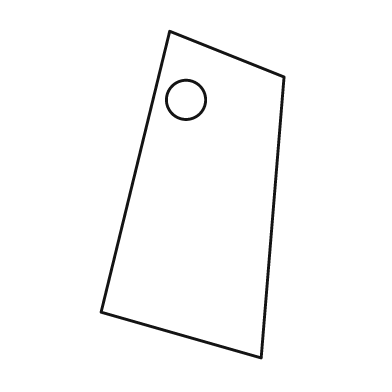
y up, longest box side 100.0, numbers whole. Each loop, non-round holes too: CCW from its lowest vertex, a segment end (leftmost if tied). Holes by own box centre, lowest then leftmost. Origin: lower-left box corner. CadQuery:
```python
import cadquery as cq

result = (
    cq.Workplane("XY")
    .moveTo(49.0, 0.0)
    .lineTo(56.0, 86.0)
    .lineTo(21.0, 100.0)
    .lineTo(0.0, 14.0)
    .close()
    .moveTo(26.0, 79.0)
    .circle(6.0)
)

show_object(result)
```